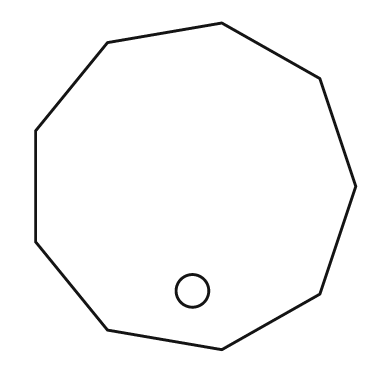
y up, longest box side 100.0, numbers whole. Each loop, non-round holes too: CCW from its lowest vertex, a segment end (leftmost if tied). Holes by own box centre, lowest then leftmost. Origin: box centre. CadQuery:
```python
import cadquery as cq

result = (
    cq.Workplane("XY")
    .moveTo(8.0, -50.0)
    .lineTo(38.0, -33.0)
    .lineTo(49.0, 0.0)
    .lineTo(38.0, 33.0)
    .lineTo(8.0, 50.0)
    .lineTo(-27.0, 44.0)
    .lineTo(-49.0, 17.0)
    .lineTo(-49.0, -17.0)
    .lineTo(-27.0, -44.0)
    .close()
    .moveTo(-1.0, -32.0)
    .circle(5.0)
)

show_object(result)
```